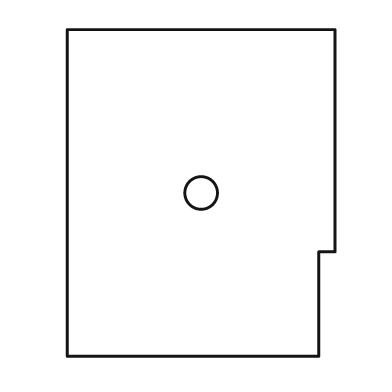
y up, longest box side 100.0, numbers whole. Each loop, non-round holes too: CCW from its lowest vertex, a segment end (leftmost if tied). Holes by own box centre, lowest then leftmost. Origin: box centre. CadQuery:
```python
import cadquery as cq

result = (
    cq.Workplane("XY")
    .moveTo(-41.0, -50.0)
    .lineTo(36.0, -50.0)
    .lineTo(36.0, -18.0)
    .lineTo(41.0, -18.0)
    .lineTo(41.0, 50.0)
    .lineTo(-41.0, 50.0)
    .close()
    .moveTo(0.0, 0.0)
    .circle(5.0)
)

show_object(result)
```